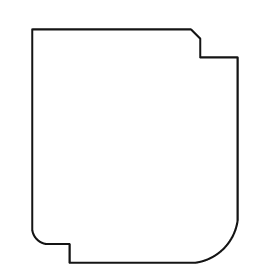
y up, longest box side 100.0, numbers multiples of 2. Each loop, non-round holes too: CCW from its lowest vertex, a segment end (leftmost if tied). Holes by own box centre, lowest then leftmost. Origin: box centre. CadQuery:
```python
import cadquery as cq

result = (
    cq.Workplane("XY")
    .moveTo(-28.0, -50.0)
    .lineTo(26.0, -50.0)
    .threePointArc((38.0, -44.0), (44.0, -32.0))
    .lineTo(44.0, 38.0)
    .lineTo(28.0, 38.0)
    .lineTo(28.0, 46.0)
    .lineTo(24.0, 50.0)
    .lineTo(-44.0, 50.0)
    .lineTo(-44.0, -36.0)
    .threePointArc((-42.0, -40.0), (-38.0, -42.0))
    .lineTo(-28.0, -42.0)
    .close()
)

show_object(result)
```